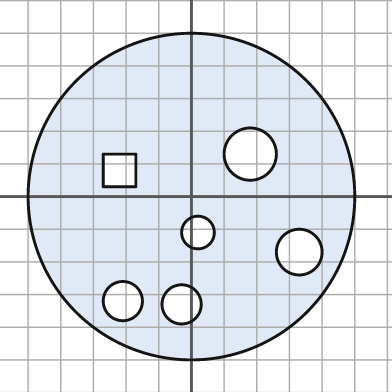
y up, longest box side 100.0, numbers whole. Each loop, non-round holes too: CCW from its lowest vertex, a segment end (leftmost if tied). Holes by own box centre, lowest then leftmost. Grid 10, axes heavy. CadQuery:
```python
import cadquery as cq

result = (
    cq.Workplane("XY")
    .moveTo(0.0, 0.0)
    .circle(50.0)
    .moveTo(-3.0, -33.0)
    .circle(6.0)
    .moveTo(-21.0, -32.0)
    .circle(6.0)
    .moveTo(33.0, -17.0)
    .circle(7.0)
    .moveTo(2.0, -11.0)
    .circle(5.0)
    .moveTo(-27.0, 3.0)
    .lineTo(-17.0, 3.0)
    .lineTo(-17.0, 13.0)
    .lineTo(-27.0, 13.0)
    .close()
    .moveTo(18.0, 13.0)
    .circle(8.0)
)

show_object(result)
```